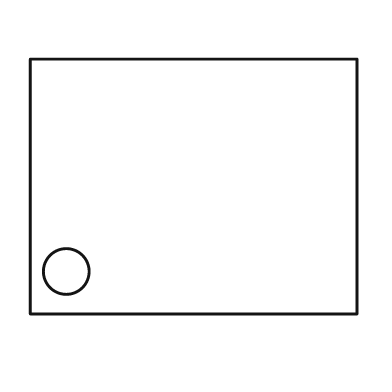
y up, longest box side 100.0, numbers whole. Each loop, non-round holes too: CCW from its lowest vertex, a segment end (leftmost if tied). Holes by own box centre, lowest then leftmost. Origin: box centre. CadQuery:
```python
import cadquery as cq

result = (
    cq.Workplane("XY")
    .moveTo(-50.0, -39.0)
    .lineTo(50.0, -39.0)
    .lineTo(50.0, 39.0)
    .lineTo(-50.0, 39.0)
    .close()
    .moveTo(-39.0, -26.0)
    .circle(7.0)
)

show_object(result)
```